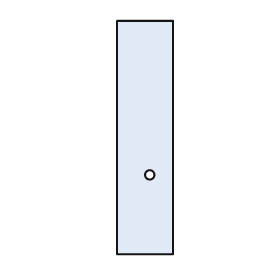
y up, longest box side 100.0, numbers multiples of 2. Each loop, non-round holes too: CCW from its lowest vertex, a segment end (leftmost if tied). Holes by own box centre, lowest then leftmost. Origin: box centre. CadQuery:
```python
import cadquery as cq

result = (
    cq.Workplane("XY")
    .moveTo(-12.0, -50.0)
    .lineTo(12.0, -50.0)
    .lineTo(12.0, 50.0)
    .lineTo(-12.0, 50.0)
    .close()
    .moveTo(2.0, -16.0)
    .circle(2.0)
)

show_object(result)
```